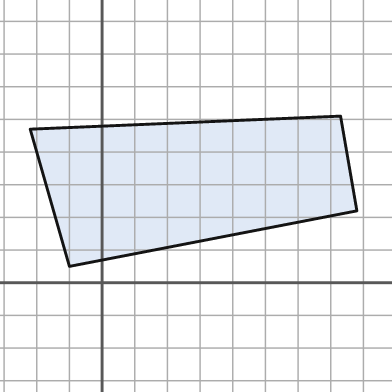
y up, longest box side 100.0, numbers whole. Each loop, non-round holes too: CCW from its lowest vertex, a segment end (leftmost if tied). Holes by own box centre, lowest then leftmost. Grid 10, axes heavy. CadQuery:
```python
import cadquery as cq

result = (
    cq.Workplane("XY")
    .moveTo(-10.0, 5.0)
    .lineTo(78.0, 22.0)
    .lineTo(73.0, 51.0)
    .lineTo(-22.0, 47.0)
    .close()
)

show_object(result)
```